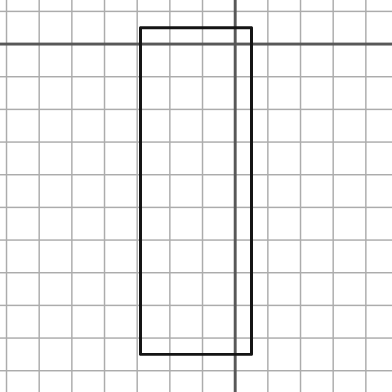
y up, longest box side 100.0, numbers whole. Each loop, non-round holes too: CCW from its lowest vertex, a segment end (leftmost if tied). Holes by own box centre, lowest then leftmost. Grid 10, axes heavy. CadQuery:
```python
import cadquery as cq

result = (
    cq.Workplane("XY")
    .moveTo(-29.0, -95.0)
    .lineTo(5.0, -95.0)
    .lineTo(5.0, 5.0)
    .lineTo(-29.0, 5.0)
    .close()
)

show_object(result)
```